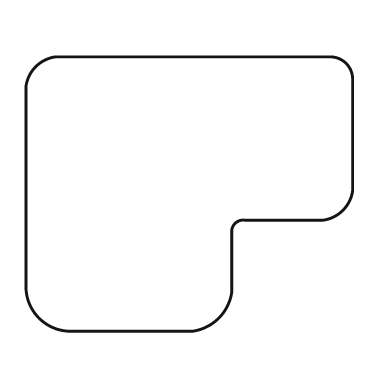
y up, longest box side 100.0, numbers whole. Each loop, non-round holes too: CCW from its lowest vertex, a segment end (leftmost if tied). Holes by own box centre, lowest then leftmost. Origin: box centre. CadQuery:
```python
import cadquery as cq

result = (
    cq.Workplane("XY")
    .moveTo(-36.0, -42.0)
    .lineTo(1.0, -42.0)
    .threePointArc((9.0, -38.0), (13.0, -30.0))
    .lineTo(13.0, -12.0)
    .threePointArc((14.0, -9.0), (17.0, -8.0))
    .lineTo(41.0, -8.0)
    .threePointArc((47.0, -5.0), (50.0, 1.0))
    .lineTo(50.0, 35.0)
    .threePointArc((48.0, 40.0), (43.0, 42.0))
    .lineTo(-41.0, 42.0)
    .threePointArc((-47.0, 39.0), (-50.0, 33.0))
    .lineTo(-50.0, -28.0)
    .threePointArc((-46.0, -38.0), (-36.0, -42.0))
    .close()
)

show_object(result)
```